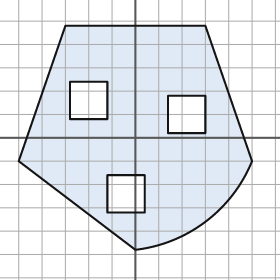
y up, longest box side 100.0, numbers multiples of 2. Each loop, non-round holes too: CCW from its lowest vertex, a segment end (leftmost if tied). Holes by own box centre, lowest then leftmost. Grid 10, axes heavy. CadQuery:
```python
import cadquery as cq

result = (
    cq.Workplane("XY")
    .moveTo(0.0, -48.0)
    .threePointArc((30.0, -36.0), (50.0, -10.0))
    .lineTo(30.0, 48.0)
    .lineTo(-30.0, 48.0)
    .lineTo(-50.0, -10.0)
    .close()
    .moveTo(-12.0, -32.0)
    .lineTo(4.0, -32.0)
    .lineTo(4.0, -16.0)
    .lineTo(-12.0, -16.0)
    .close()
    .moveTo(14.0, 2.0)
    .lineTo(30.0, 2.0)
    .lineTo(30.0, 18.0)
    .lineTo(14.0, 18.0)
    .close()
    .moveTo(-28.0, 8.0)
    .lineTo(-12.0, 8.0)
    .lineTo(-12.0, 24.0)
    .lineTo(-28.0, 24.0)
    .close()
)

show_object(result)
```